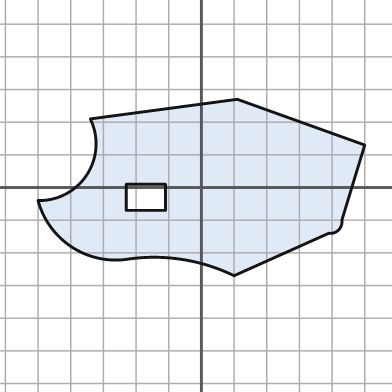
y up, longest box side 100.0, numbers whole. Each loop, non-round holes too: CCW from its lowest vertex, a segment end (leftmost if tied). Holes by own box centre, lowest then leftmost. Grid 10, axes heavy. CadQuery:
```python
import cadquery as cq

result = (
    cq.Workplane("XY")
    .moveTo(10.0, -27.0)
    .lineTo(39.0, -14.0)
    .threePointArc((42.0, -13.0), (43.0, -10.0))
    .lineTo(50.0, 13.0)
    .lineTo(11.0, 27.0)
    .lineTo(-34.0, 21.0)
    .threePointArc((-35.0, 4.0), (-50.0, -4.0))
    .threePointArc((-40.0, -18.0), (-23.0, -22.0))
    .threePointArc((-6.0, -22.0), (10.0, -27.0))
    .close()
    .moveTo(-23.0, -7.0)
    .lineTo(-11.0, -7.0)
    .lineTo(-11.0, 1.0)
    .lineTo(-23.0, 1.0)
    .close()
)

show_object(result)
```